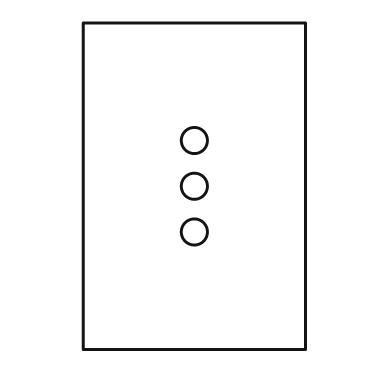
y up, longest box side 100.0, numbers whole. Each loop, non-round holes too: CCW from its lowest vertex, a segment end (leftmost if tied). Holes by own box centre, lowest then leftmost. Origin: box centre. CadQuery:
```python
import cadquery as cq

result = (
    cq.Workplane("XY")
    .moveTo(-34.0, -50.0)
    .lineTo(34.0, -50.0)
    .lineTo(34.0, 50.0)
    .lineTo(-34.0, 50.0)
    .close()
    .moveTo(0.0, -14.0)
    .circle(4.0)
    .moveTo(0.0, 0.0)
    .circle(4.0)
    .moveTo(0.0, 14.0)
    .circle(4.0)
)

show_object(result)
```